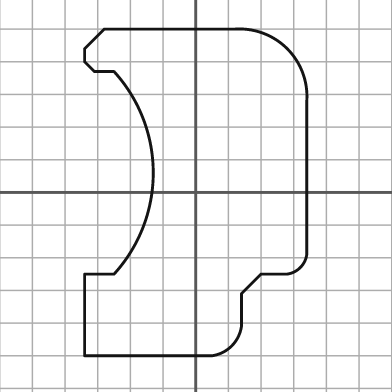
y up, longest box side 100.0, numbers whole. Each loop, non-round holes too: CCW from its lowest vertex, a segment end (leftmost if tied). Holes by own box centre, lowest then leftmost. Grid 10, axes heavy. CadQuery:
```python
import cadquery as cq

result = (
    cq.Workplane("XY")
    .moveTo(-34.0, -50.0)
    .lineTo(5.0, -50.0)
    .threePointArc((11.0, -47.0), (14.0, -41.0))
    .lineTo(14.0, -31.0)
    .lineTo(20.0, -25.0)
    .lineTo(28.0, -25.0)
    .threePointArc((32.0, -23.0), (34.0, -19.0))
    .lineTo(34.0, 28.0)
    .threePointArc((28.0, 44.0), (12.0, 50.0))
    .lineTo(-28.0, 50.0)
    .lineTo(-34.0, 44.0)
    .lineTo(-34.0, 40.0)
    .lineTo(-31.0, 37.0)
    .lineTo(-25.0, 37.0)
    .threePointArc((-13.0, 6.0), (-25.0, -25.0))
    .lineTo(-34.0, -25.0)
    .close()
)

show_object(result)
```